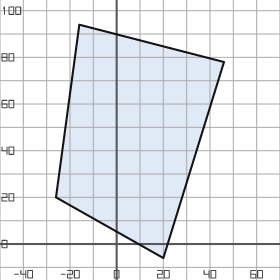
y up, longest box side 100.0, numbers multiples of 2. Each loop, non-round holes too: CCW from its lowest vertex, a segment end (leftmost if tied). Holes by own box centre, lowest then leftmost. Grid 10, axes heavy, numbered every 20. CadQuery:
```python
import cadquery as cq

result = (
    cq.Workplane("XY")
    .moveTo(20.0, -6.0)
    .lineTo(46.0, 78.0)
    .lineTo(-16.0, 94.0)
    .lineTo(-26.0, 20.0)
    .close()
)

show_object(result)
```